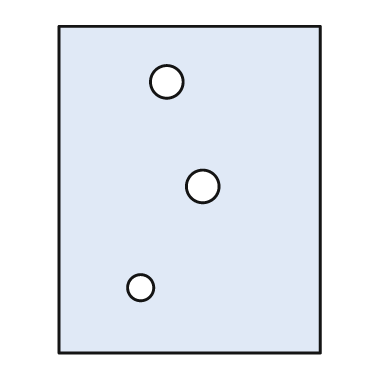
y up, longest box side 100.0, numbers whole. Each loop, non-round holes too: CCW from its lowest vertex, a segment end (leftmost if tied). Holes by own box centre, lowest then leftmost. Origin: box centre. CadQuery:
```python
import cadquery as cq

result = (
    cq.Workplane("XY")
    .moveTo(-40.0, -50.0)
    .lineTo(40.0, -50.0)
    .lineTo(40.0, 50.0)
    .lineTo(-40.0, 50.0)
    .close()
    .moveTo(-15.0, -30.0)
    .circle(4.0)
    .moveTo(4.0, 1.0)
    .circle(5.0)
    .moveTo(-7.0, 33.0)
    .circle(5.0)
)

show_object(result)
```